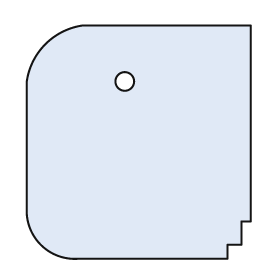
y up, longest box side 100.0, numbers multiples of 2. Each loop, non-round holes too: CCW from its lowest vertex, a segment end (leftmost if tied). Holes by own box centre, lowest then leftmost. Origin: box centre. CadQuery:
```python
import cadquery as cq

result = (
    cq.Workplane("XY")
    .moveTo(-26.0, -50.0)
    .lineTo(38.0, -50.0)
    .lineTo(38.0, -44.0)
    .lineTo(44.0, -44.0)
    .lineTo(44.0, -34.0)
    .lineTo(48.0, -34.0)
    .lineTo(48.0, 50.0)
    .lineTo(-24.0, 50.0)
    .threePointArc((-40.0, 42.0), (-48.0, 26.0))
    .lineTo(-48.0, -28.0)
    .threePointArc((-42.0, -44.0), (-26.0, -50.0))
    .close()
    .moveTo(-6.0, 26.0)
    .circle(4.0)
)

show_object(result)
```